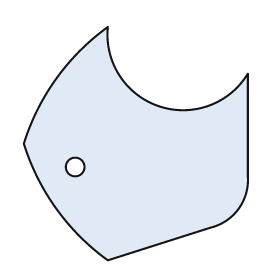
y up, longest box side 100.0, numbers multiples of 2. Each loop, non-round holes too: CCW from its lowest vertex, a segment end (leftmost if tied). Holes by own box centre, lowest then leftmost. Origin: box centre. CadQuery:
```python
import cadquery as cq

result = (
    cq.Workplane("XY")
    .moveTo(-12.0, -50.0)
    .lineTo(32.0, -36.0)
    .threePointArc((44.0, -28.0), (48.0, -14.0))
    .lineTo(48.0, 30.0)
    .threePointArc((10.0, 16.0), (-12.0, 50.0))
    .threePointArc((-34.0, 28.0), (-48.0, 0.0))
    .threePointArc((-34.0, -28.0), (-12.0, -50.0))
    .close()
    .moveTo(-26.0, -10.0)
    .circle(4.0)
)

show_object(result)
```